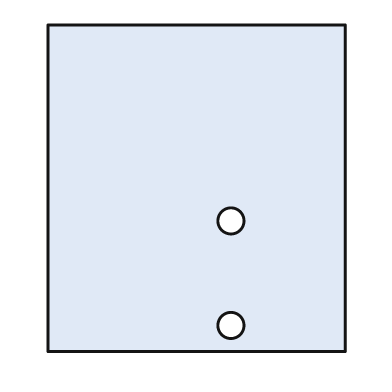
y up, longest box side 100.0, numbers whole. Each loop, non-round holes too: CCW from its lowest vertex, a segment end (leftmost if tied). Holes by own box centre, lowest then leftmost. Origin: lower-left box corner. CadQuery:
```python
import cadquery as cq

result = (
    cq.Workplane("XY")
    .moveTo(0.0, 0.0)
    .lineTo(91.0, 0.0)
    .lineTo(91.0, 100.0)
    .lineTo(0.0, 100.0)
    .close()
    .moveTo(56.0, 8.0)
    .circle(4.0)
    .moveTo(56.0, 40.0)
    .circle(4.0)
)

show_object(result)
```